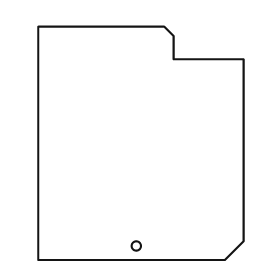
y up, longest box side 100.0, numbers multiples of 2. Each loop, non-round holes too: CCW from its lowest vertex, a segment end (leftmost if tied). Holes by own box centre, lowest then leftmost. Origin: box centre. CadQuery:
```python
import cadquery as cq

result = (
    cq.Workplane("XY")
    .moveTo(-44.0, -50.0)
    .lineTo(36.0, -50.0)
    .lineTo(44.0, -42.0)
    .lineTo(44.0, 36.0)
    .lineTo(14.0, 36.0)
    .lineTo(14.0, 46.0)
    .lineTo(10.0, 50.0)
    .lineTo(-44.0, 50.0)
    .close()
    .moveTo(-2.0, -44.0)
    .circle(2.0)
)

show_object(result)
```